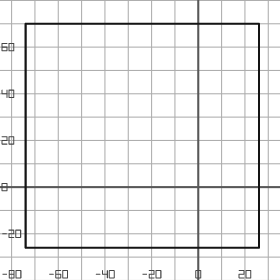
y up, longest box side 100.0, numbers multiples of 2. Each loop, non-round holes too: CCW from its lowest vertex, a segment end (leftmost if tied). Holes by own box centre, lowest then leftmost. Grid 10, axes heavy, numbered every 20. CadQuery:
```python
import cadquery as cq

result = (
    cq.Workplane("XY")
    .moveTo(-74.0, -26.0)
    .lineTo(26.0, -26.0)
    .lineTo(26.0, 70.0)
    .lineTo(-74.0, 70.0)
    .close()
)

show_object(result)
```